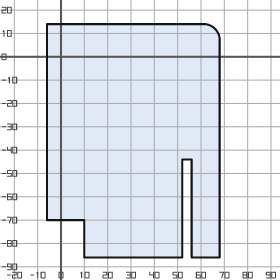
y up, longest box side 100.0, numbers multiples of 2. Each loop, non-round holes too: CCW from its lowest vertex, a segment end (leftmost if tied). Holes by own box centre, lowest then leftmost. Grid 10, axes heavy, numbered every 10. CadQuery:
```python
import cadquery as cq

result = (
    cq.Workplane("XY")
    .moveTo(10.0, -86.0)
    .lineTo(52.0, -86.0)
    .lineTo(52.0, -44.0)
    .lineTo(56.0, -44.0)
    .lineTo(56.0, -86.0)
    .lineTo(68.0, -86.0)
    .lineTo(68.0, 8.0)
    .threePointArc((66.0, 12.0), (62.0, 14.0))
    .lineTo(-6.0, 14.0)
    .lineTo(-6.0, -70.0)
    .lineTo(10.0, -70.0)
    .close()
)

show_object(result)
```